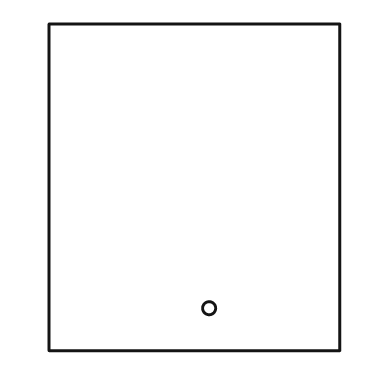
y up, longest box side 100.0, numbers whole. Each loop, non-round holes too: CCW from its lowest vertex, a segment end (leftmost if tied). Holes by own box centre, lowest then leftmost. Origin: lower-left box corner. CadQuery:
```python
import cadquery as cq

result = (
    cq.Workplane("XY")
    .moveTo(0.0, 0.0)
    .lineTo(89.0, 0.0)
    .lineTo(89.0, 100.0)
    .lineTo(0.0, 100.0)
    .close()
    .moveTo(49.0, 13.0)
    .circle(2.0)
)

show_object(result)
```